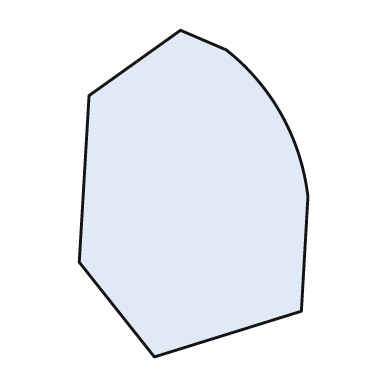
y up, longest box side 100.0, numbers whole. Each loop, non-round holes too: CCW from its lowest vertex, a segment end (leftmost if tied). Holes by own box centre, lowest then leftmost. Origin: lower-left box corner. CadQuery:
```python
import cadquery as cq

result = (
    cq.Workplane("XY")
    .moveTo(23.0, 0.0)
    .lineTo(68.0, 14.0)
    .lineTo(70.0, 49.0)
    .threePointArc((62.0, 74.0), (45.0, 94.0))
    .lineTo(31.0, 100.0)
    .lineTo(3.0, 80.0)
    .lineTo(0.0, 29.0)
    .close()
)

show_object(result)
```